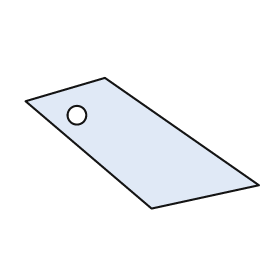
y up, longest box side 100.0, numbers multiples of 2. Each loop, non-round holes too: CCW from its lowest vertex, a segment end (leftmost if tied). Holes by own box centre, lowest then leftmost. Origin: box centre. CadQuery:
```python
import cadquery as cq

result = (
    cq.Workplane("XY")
    .moveTo(4.0, -28.0)
    .lineTo(50.0, -18.0)
    .lineTo(-16.0, 28.0)
    .lineTo(-50.0, 18.0)
    .close()
    .moveTo(-28.0, 12.0)
    .circle(4.0)
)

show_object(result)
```